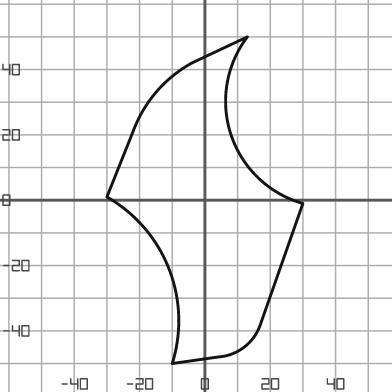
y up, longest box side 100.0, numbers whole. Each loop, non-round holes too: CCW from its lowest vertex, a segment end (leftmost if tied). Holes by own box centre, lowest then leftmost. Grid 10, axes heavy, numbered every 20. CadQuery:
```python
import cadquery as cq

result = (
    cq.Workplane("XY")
    .moveTo(-10.0, -50.0)
    .lineTo(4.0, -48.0)
    .threePointArc((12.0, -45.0), (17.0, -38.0))
    .lineTo(30.0, -1.0)
    .threePointArc((8.0, 20.0), (13.0, 50.0))
    .lineTo(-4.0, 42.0)
    .threePointArc((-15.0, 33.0), (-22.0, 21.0))
    .lineTo(-30.0, 1.0)
    .threePointArc((-11.0, -21.0), (-10.0, -50.0))
    .close()
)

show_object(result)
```